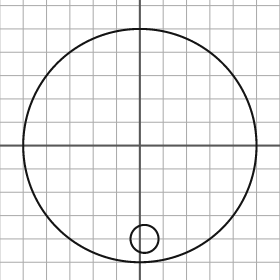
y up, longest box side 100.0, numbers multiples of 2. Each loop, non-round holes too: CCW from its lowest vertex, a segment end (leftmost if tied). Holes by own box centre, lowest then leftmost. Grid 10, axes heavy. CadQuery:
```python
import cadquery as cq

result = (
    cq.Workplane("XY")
    .moveTo(0.0, 0.0)
    .circle(50.0)
    .moveTo(2.0, -40.0)
    .circle(6.0)
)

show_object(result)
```